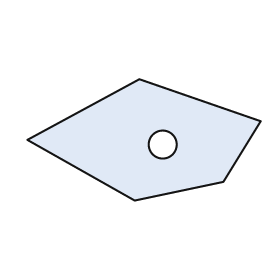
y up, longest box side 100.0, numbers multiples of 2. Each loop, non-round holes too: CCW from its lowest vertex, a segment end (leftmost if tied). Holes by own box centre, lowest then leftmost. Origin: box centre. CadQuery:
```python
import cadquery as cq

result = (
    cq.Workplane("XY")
    .moveTo(-4.0, -26.0)
    .lineTo(34.0, -18.0)
    .lineTo(50.0, 8.0)
    .lineTo(-2.0, 26.0)
    .lineTo(-50.0, 0.0)
    .close()
    .moveTo(8.0, -2.0)
    .circle(6.0)
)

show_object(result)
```